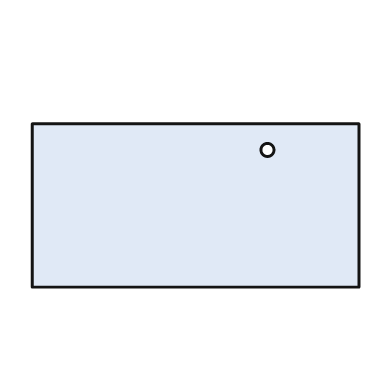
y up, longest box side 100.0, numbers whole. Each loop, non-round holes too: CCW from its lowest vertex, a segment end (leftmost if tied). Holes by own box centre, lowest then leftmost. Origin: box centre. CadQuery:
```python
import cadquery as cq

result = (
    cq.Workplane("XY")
    .moveTo(-50.0, -25.0)
    .lineTo(50.0, -25.0)
    .lineTo(50.0, 25.0)
    .lineTo(-50.0, 25.0)
    .close()
    .moveTo(22.0, 17.0)
    .circle(2.0)
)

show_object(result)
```